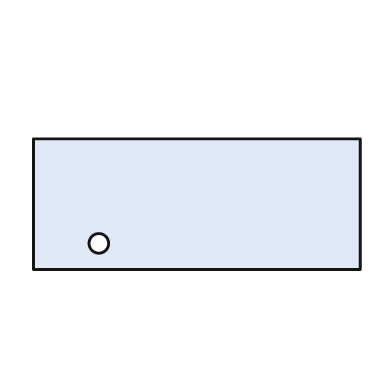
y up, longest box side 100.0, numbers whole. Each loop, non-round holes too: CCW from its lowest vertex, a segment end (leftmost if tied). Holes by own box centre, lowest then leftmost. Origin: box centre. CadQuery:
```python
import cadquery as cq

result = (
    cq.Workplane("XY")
    .moveTo(-50.0, -20.0)
    .lineTo(50.0, -20.0)
    .lineTo(50.0, 20.0)
    .lineTo(-50.0, 20.0)
    .close()
    .moveTo(-30.0, -12.0)
    .circle(3.0)
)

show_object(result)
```